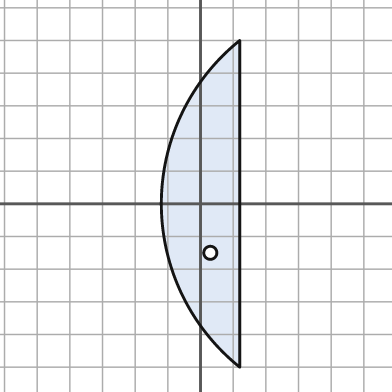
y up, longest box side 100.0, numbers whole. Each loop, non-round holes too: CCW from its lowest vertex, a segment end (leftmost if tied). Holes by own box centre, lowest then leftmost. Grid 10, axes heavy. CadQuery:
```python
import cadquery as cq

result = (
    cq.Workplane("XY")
    .moveTo(12.0, -50.0)
    .lineTo(12.0, 50.0)
    .threePointArc((-12.0, 0.0), (12.0, -50.0))
    .close()
    .moveTo(3.0, -15.0)
    .circle(2.0)
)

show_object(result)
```